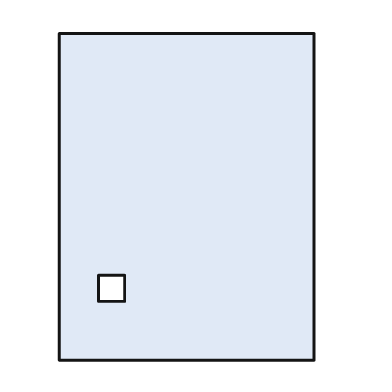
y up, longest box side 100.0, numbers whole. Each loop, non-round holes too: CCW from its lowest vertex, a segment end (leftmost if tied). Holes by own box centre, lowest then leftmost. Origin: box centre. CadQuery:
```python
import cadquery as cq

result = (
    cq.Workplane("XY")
    .moveTo(-39.0, -50.0)
    .lineTo(39.0, -50.0)
    .lineTo(39.0, 50.0)
    .lineTo(-39.0, 50.0)
    .close()
    .moveTo(-27.0, -32.0)
    .lineTo(-19.0, -32.0)
    .lineTo(-19.0, -24.0)
    .lineTo(-27.0, -24.0)
    .close()
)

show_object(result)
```